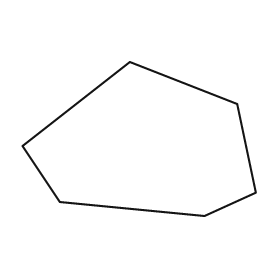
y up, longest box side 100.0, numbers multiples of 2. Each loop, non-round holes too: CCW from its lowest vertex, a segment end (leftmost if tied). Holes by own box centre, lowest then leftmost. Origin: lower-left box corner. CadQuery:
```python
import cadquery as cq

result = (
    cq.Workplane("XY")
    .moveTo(78.0, 0.0)
    .lineTo(100.0, 10.0)
    .lineTo(92.0, 48.0)
    .lineTo(46.0, 66.0)
    .lineTo(0.0, 30.0)
    .lineTo(16.0, 6.0)
    .close()
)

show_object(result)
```